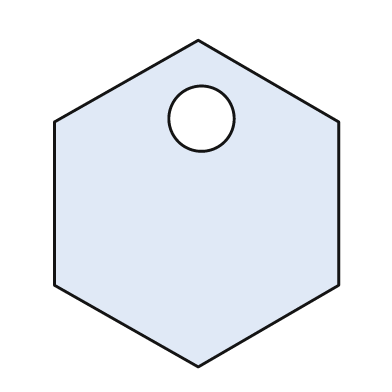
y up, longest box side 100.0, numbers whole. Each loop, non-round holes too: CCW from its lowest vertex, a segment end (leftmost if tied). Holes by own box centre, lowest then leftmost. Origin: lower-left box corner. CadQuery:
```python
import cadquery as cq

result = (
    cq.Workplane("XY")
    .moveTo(44.0, 0.0)
    .lineTo(87.0, 25.0)
    .lineTo(87.0, 75.0)
    .lineTo(44.0, 100.0)
    .lineTo(0.0, 75.0)
    .lineTo(0.0, 25.0)
    .close()
    .moveTo(45.0, 76.0)
    .circle(10.0)
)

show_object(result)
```